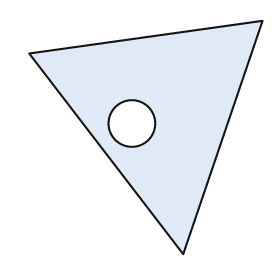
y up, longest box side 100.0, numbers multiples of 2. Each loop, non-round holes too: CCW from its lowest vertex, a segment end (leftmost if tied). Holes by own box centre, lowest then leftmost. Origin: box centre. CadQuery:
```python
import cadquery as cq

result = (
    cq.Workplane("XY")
    .moveTo(16.0, -50.0)
    .lineTo(50.0, 50.0)
    .lineTo(-50.0, 36.0)
    .close()
    .moveTo(-6.0, 6.0)
    .circle(10.0)
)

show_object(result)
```